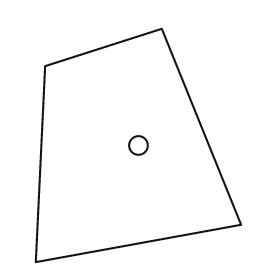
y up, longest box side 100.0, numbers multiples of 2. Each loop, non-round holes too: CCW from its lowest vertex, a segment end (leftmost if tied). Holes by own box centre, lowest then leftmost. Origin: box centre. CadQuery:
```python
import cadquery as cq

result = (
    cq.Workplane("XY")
    .moveTo(-44.0, -50.0)
    .lineTo(44.0, -34.0)
    .lineTo(10.0, 50.0)
    .lineTo(-40.0, 34.0)
    .close()
    .moveTo(0.0, 0.0)
    .circle(4.0)
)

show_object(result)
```